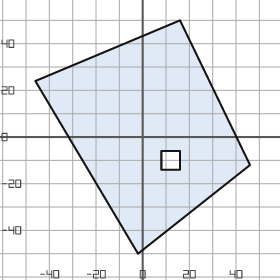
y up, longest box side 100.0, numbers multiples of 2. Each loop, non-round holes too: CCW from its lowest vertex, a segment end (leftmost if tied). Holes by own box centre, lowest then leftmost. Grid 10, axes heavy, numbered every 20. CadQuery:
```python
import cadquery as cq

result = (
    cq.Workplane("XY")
    .moveTo(-2.0, -50.0)
    .lineTo(46.0, -12.0)
    .lineTo(16.0, 50.0)
    .lineTo(-46.0, 24.0)
    .close()
    .moveTo(8.0, -14.0)
    .lineTo(16.0, -14.0)
    .lineTo(16.0, -6.0)
    .lineTo(8.0, -6.0)
    .close()
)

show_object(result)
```